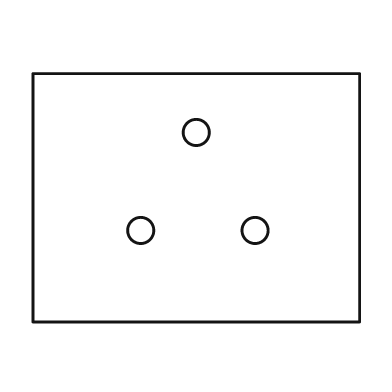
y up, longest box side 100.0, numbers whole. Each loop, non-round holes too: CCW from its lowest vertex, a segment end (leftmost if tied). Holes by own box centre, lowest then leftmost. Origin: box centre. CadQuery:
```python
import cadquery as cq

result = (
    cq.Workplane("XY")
    .moveTo(-50.0, -38.0)
    .lineTo(50.0, -38.0)
    .lineTo(50.0, 38.0)
    .lineTo(-50.0, 38.0)
    .close()
    .moveTo(-17.0, -10.0)
    .circle(4.0)
    .moveTo(18.0, -10.0)
    .circle(4.0)
    .moveTo(0.0, 20.0)
    .circle(4.0)
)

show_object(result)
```